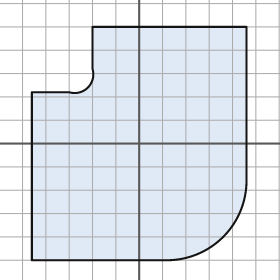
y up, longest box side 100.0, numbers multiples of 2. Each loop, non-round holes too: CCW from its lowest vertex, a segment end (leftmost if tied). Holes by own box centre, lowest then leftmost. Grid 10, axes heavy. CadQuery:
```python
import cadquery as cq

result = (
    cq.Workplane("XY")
    .moveTo(-46.0, -50.0)
    .lineTo(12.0, -50.0)
    .threePointArc((36.0, -40.0), (46.0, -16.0))
    .lineTo(46.0, 50.0)
    .lineTo(-20.0, 50.0)
    .lineTo(-20.0, 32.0)
    .threePointArc((-22.0, 24.0), (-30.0, 22.0))
    .lineTo(-46.0, 22.0)
    .close()
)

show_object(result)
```